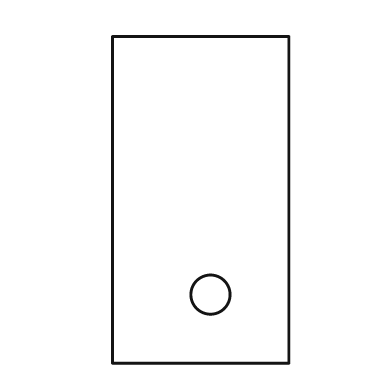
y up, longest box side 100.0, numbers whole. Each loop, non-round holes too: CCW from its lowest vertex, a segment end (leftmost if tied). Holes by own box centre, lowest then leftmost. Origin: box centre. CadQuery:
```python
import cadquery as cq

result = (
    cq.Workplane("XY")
    .moveTo(-27.0, -50.0)
    .lineTo(27.0, -50.0)
    .lineTo(27.0, 50.0)
    .lineTo(-27.0, 50.0)
    .close()
    .moveTo(3.0, -29.0)
    .circle(6.0)
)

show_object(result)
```